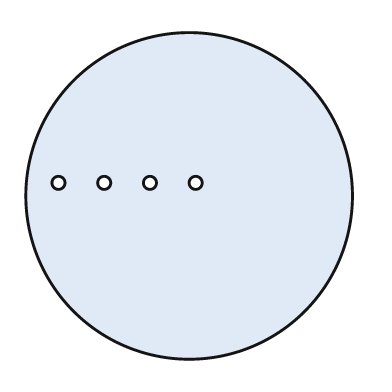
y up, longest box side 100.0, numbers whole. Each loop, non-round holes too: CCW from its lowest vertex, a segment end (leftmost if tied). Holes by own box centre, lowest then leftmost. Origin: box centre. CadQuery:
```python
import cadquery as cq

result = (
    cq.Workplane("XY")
    .moveTo(0.0, 0.0)
    .circle(50.0)
    .moveTo(-40.0, 4.0)
    .circle(2.0)
    .moveTo(-26.0, 4.0)
    .circle(2.0)
    .moveTo(-12.0, 4.0)
    .circle(2.0)
    .moveTo(2.0, 4.0)
    .circle(2.0)
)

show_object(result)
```